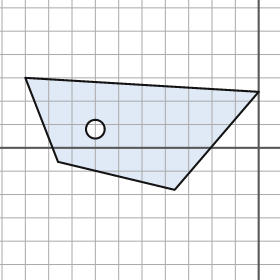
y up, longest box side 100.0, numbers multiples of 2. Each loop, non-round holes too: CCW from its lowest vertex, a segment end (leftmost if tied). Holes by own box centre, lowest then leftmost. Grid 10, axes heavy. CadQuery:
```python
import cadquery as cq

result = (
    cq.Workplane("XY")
    .moveTo(-36.0, -18.0)
    .lineTo(0.0, 24.0)
    .lineTo(-100.0, 30.0)
    .lineTo(-86.0, -6.0)
    .close()
    .moveTo(-70.0, 8.0)
    .circle(4.0)
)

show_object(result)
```